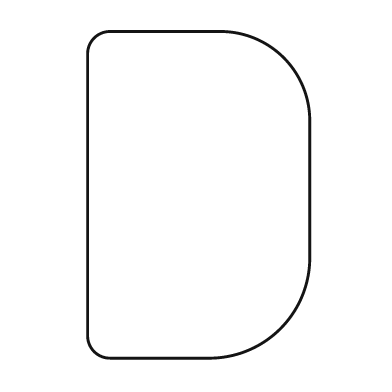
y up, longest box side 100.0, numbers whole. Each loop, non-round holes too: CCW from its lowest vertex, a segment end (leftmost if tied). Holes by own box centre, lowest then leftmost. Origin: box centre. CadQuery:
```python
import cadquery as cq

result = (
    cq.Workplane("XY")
    .moveTo(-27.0, -50.0)
    .lineTo(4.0, -50.0)
    .threePointArc((25.0, -41.0), (34.0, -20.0))
    .lineTo(34.0, 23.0)
    .threePointArc((26.0, 42.0), (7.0, 50.0))
    .lineTo(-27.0, 50.0)
    .threePointArc((-32.0, 48.0), (-34.0, 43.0))
    .lineTo(-34.0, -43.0)
    .threePointArc((-32.0, -48.0), (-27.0, -50.0))
    .close()
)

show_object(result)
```